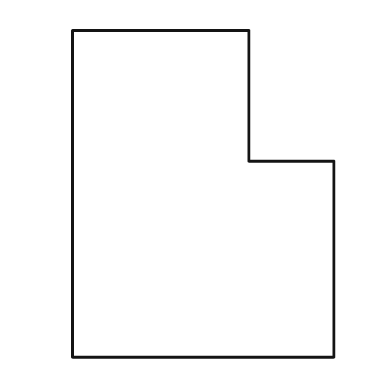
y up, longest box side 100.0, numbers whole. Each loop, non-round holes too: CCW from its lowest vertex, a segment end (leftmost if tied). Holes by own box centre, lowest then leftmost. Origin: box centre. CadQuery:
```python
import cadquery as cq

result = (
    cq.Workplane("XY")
    .moveTo(-40.0, -50.0)
    .lineTo(40.0, -50.0)
    .lineTo(40.0, 10.0)
    .lineTo(14.0, 10.0)
    .lineTo(14.0, 50.0)
    .lineTo(-40.0, 50.0)
    .close()
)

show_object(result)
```